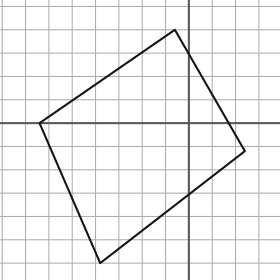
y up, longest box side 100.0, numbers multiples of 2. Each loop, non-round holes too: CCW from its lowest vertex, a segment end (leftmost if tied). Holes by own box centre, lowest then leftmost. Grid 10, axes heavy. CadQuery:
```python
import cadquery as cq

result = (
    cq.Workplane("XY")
    .moveTo(-38.0, -60.0)
    .lineTo(24.0, -12.0)
    .lineTo(-6.0, 40.0)
    .lineTo(-64.0, 0.0)
    .close()
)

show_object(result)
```